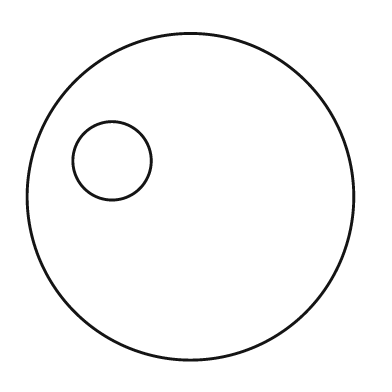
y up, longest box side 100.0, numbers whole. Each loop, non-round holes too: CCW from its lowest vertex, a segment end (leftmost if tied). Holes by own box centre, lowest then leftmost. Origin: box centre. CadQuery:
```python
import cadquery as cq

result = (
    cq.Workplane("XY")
    .moveTo(0.0, 0.0)
    .circle(50.0)
    .moveTo(-24.0, 11.0)
    .circle(12.0)
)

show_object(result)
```